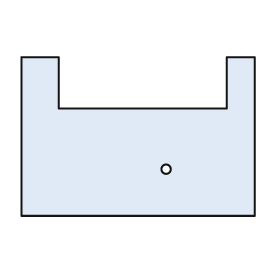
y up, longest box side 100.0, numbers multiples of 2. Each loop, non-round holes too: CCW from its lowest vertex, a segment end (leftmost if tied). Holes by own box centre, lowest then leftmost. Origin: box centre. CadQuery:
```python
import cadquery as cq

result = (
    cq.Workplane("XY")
    .moveTo(-50.0, -34.0)
    .lineTo(50.0, -34.0)
    .lineTo(50.0, 34.0)
    .lineTo(38.0, 34.0)
    .lineTo(38.0, 12.0)
    .lineTo(-34.0, 12.0)
    .lineTo(-34.0, 34.0)
    .lineTo(-50.0, 34.0)
    .close()
    .moveTo(12.0, -14.0)
    .circle(2.0)
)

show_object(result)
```